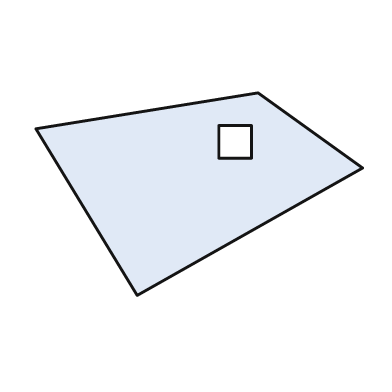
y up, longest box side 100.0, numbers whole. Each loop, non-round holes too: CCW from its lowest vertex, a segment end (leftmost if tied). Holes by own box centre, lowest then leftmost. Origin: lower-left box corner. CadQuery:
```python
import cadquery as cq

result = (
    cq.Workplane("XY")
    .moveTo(31.0, 0.0)
    .lineTo(100.0, 39.0)
    .lineTo(68.0, 62.0)
    .lineTo(0.0, 51.0)
    .close()
    .moveTo(56.0, 42.0)
    .lineTo(66.0, 42.0)
    .lineTo(66.0, 52.0)
    .lineTo(56.0, 52.0)
    .close()
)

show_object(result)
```